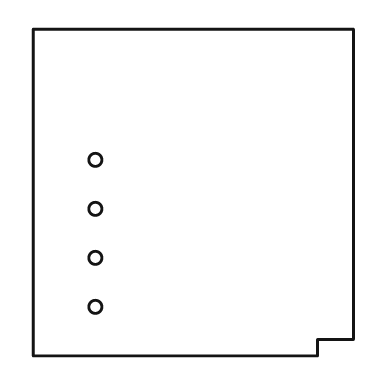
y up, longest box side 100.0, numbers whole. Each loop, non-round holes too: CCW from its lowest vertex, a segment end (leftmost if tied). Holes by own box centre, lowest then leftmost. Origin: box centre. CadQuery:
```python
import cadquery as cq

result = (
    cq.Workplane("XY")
    .moveTo(-49.0, -50.0)
    .lineTo(38.0, -50.0)
    .lineTo(38.0, -45.0)
    .lineTo(49.0, -45.0)
    .lineTo(49.0, 50.0)
    .lineTo(-49.0, 50.0)
    .close()
    .moveTo(-30.0, -35.0)
    .circle(2.0)
    .moveTo(-30.0, -20.0)
    .circle(2.0)
    .moveTo(-30.0, -5.0)
    .circle(2.0)
    .moveTo(-30.0, 10.0)
    .circle(2.0)
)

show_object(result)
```